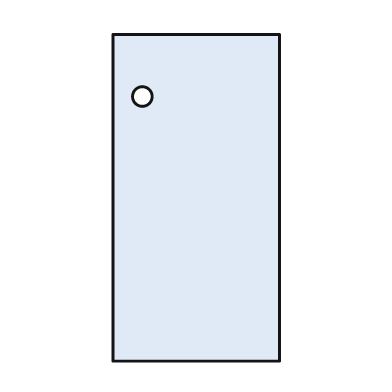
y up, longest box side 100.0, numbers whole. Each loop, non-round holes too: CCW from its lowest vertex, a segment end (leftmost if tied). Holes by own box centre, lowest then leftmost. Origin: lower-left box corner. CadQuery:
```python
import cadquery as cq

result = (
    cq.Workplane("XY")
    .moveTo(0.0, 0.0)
    .lineTo(51.0, 0.0)
    .lineTo(51.0, 100.0)
    .lineTo(0.0, 100.0)
    .close()
    .moveTo(9.0, 81.0)
    .circle(3.0)
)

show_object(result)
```